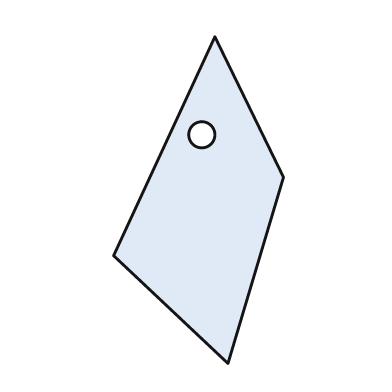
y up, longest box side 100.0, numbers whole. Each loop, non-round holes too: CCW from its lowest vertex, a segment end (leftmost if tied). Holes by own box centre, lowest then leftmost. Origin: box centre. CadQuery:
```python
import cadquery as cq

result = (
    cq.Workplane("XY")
    .moveTo(9.0, -50.0)
    .lineTo(26.0, 7.0)
    .lineTo(5.0, 50.0)
    .lineTo(-26.0, -17.0)
    .close()
    .moveTo(1.0, 20.0)
    .circle(4.0)
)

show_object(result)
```